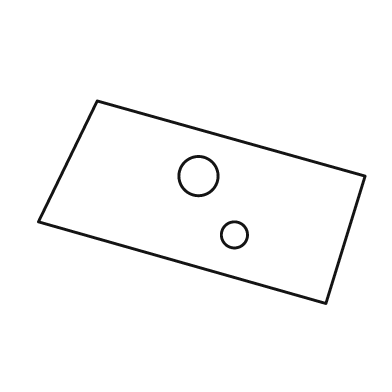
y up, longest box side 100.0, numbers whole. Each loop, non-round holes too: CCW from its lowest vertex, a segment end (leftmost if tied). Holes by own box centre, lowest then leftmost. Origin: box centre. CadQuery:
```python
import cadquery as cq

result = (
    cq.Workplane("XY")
    .moveTo(38.0, -31.0)
    .lineTo(50.0, 8.0)
    .lineTo(-32.0, 31.0)
    .lineTo(-50.0, -6.0)
    .close()
    .moveTo(10.0, -10.0)
    .circle(4.0)
    .moveTo(-1.0, 8.0)
    .circle(6.0)
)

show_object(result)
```